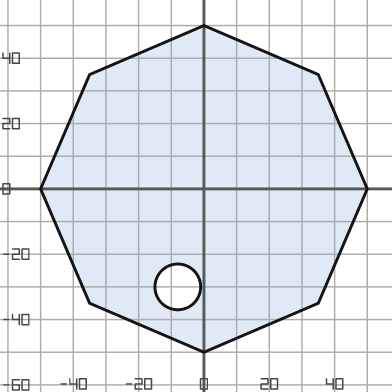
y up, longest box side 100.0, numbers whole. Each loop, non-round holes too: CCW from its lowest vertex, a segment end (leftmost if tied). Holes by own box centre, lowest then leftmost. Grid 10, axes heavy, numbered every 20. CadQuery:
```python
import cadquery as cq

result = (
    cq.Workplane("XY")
    .moveTo(0.0, -50.0)
    .lineTo(35.0, -35.0)
    .lineTo(50.0, 0.0)
    .lineTo(35.0, 35.0)
    .lineTo(0.0, 50.0)
    .lineTo(-35.0, 35.0)
    .lineTo(-50.0, 0.0)
    .lineTo(-35.0, -35.0)
    .close()
    .moveTo(-8.0, -30.0)
    .circle(7.0)
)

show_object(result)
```